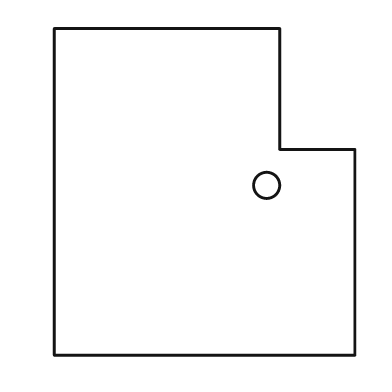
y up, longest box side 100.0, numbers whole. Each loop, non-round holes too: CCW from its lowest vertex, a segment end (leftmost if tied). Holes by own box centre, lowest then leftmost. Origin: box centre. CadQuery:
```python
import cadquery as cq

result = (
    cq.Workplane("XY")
    .moveTo(-46.0, -50.0)
    .lineTo(46.0, -50.0)
    .lineTo(46.0, 13.0)
    .lineTo(23.0, 13.0)
    .lineTo(23.0, 50.0)
    .lineTo(-46.0, 50.0)
    .close()
    .moveTo(19.0, 2.0)
    .circle(4.0)
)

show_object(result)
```